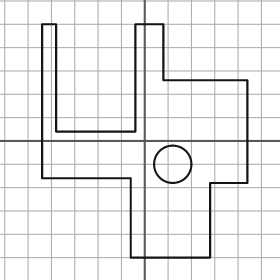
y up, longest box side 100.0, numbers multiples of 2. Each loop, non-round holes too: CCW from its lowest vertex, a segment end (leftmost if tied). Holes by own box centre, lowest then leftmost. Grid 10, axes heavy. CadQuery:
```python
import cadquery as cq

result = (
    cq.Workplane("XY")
    .moveTo(-6.0, -50.0)
    .lineTo(28.0, -50.0)
    .lineTo(28.0, -18.0)
    .lineTo(44.0, -18.0)
    .lineTo(44.0, 26.0)
    .lineTo(8.0, 26.0)
    .lineTo(8.0, 50.0)
    .lineTo(-4.0, 50.0)
    .lineTo(-4.0, 4.0)
    .lineTo(-38.0, 4.0)
    .lineTo(-38.0, 50.0)
    .lineTo(-44.0, 50.0)
    .lineTo(-44.0, -16.0)
    .lineTo(-6.0, -16.0)
    .close()
    .moveTo(12.0, -10.0)
    .circle(8.0)
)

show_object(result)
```